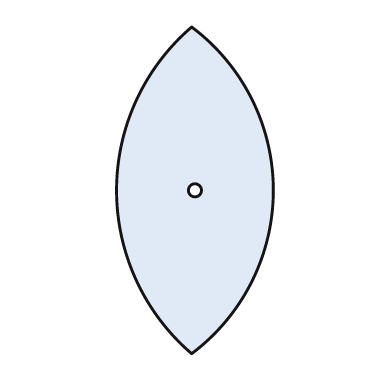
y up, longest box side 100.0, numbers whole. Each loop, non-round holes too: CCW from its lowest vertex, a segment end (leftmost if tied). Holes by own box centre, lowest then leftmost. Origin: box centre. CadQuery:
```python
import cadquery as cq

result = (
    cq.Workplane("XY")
    .moveTo(-1.0, -50.0)
    .threePointArc((24.0, 0.0), (-1.0, 50.0))
    .threePointArc((-24.0, 0.0), (-1.0, -50.0))
    .close()
    .moveTo(0.0, 0.0)
    .circle(2.0)
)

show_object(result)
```